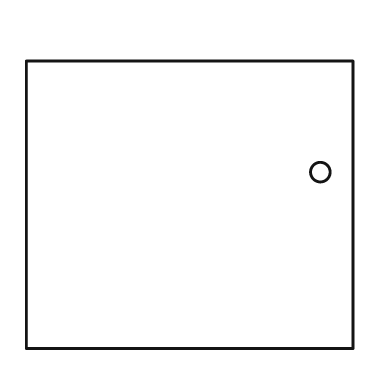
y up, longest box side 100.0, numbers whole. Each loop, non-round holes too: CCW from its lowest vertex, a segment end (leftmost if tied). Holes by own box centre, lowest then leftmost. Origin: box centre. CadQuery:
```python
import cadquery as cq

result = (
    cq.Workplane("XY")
    .moveTo(-50.0, -44.0)
    .lineTo(50.0, -44.0)
    .lineTo(50.0, 44.0)
    .lineTo(-50.0, 44.0)
    .close()
    .moveTo(40.0, 10.0)
    .circle(3.0)
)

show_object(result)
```